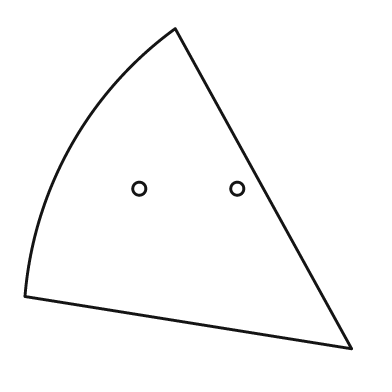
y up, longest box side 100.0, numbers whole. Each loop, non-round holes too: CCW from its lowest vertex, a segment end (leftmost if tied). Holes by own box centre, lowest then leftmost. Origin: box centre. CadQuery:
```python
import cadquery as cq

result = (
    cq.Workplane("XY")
    .moveTo(50.0, -49.0)
    .lineTo(-4.0, 49.0)
    .threePointArc((-36.0, 13.0), (-50.0, -33.0))
    .close()
    .moveTo(-15.0, 0.0)
    .circle(2.0)
    .moveTo(15.0, 0.0)
    .circle(2.0)
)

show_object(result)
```